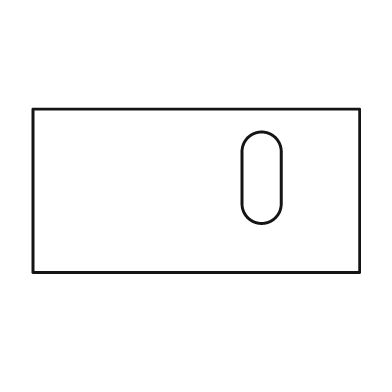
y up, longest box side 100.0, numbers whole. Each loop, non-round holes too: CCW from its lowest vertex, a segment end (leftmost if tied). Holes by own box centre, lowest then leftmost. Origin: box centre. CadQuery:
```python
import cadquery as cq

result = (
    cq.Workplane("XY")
    .moveTo(-50.0, -25.0)
    .lineTo(50.0, -25.0)
    .lineTo(50.0, 25.0)
    .lineTo(-50.0, 25.0)
    .close()
    .moveTo(14.0, -4.0)
    .threePointArc((20.0, -10.0), (26.0, -4.0))
    .lineTo(26.0, 12.0)
    .threePointArc((20.0, 18.0), (14.0, 12.0))
    .close()
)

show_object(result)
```